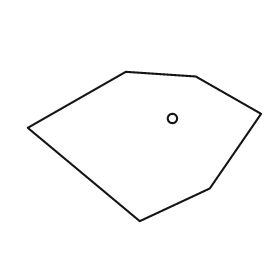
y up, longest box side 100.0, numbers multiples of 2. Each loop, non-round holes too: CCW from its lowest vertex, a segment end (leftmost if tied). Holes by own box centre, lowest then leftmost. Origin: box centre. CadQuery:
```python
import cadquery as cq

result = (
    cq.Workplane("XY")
    .moveTo(-2.0, -32.0)
    .lineTo(28.0, -18.0)
    .lineTo(50.0, 14.0)
    .lineTo(22.0, 30.0)
    .lineTo(-8.0, 32.0)
    .lineTo(-50.0, 8.0)
    .close()
    .moveTo(12.0, 12.0)
    .circle(2.0)
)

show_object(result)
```